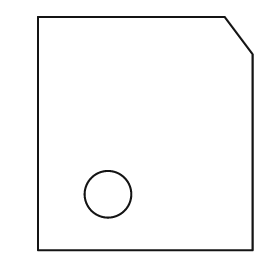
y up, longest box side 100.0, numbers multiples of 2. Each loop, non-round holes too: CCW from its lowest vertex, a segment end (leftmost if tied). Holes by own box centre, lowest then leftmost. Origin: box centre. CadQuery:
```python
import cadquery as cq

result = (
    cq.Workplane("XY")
    .moveTo(-46.0, -50.0)
    .lineTo(46.0, -50.0)
    .lineTo(46.0, 34.0)
    .lineTo(34.0, 50.0)
    .lineTo(-46.0, 50.0)
    .close()
    .moveTo(-16.0, -26.0)
    .circle(10.0)
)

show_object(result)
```